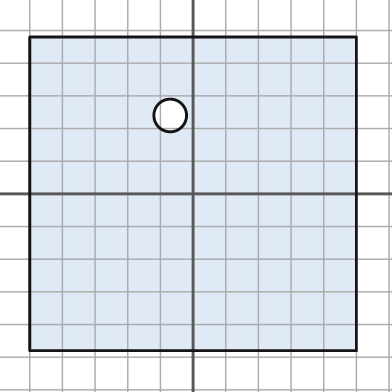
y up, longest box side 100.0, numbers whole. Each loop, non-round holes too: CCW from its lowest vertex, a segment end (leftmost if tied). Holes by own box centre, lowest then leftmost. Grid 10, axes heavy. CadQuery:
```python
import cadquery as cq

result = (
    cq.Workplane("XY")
    .moveTo(-50.0, -48.0)
    .lineTo(50.0, -48.0)
    .lineTo(50.0, 48.0)
    .lineTo(-50.0, 48.0)
    .close()
    .moveTo(-7.0, 24.0)
    .circle(5.0)
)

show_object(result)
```